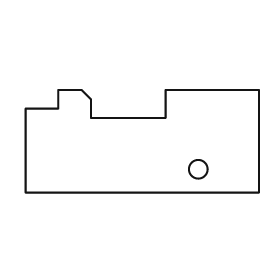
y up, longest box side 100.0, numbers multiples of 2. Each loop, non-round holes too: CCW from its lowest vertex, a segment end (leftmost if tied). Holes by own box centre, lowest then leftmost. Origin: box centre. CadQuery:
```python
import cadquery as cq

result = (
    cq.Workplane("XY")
    .moveTo(-50.0, -22.0)
    .lineTo(50.0, -22.0)
    .lineTo(50.0, 22.0)
    .lineTo(10.0, 22.0)
    .lineTo(10.0, 10.0)
    .lineTo(-22.0, 10.0)
    .lineTo(-22.0, 18.0)
    .lineTo(-26.0, 22.0)
    .lineTo(-36.0, 22.0)
    .lineTo(-36.0, 14.0)
    .lineTo(-50.0, 14.0)
    .close()
    .moveTo(24.0, -12.0)
    .circle(4.0)
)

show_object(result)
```